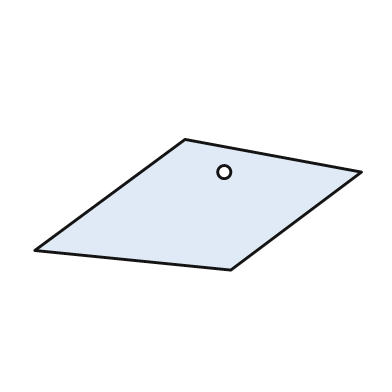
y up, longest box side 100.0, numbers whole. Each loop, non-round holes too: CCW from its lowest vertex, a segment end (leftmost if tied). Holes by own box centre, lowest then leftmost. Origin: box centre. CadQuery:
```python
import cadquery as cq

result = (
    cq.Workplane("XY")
    .moveTo(10.0, -20.0)
    .lineTo(50.0, 10.0)
    .lineTo(-4.0, 20.0)
    .lineTo(-50.0, -14.0)
    .close()
    .moveTo(8.0, 10.0)
    .circle(2.0)
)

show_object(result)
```